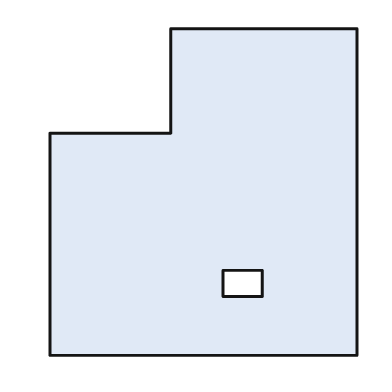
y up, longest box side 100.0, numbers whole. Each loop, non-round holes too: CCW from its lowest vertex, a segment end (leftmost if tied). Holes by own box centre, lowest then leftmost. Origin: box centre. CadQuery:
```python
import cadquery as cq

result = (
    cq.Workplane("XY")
    .moveTo(-47.0, -50.0)
    .lineTo(47.0, -50.0)
    .lineTo(47.0, 50.0)
    .lineTo(-10.0, 50.0)
    .lineTo(-10.0, 18.0)
    .lineTo(-47.0, 18.0)
    .close()
    .moveTo(6.0, -32.0)
    .lineTo(18.0, -32.0)
    .lineTo(18.0, -24.0)
    .lineTo(6.0, -24.0)
    .close()
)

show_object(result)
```